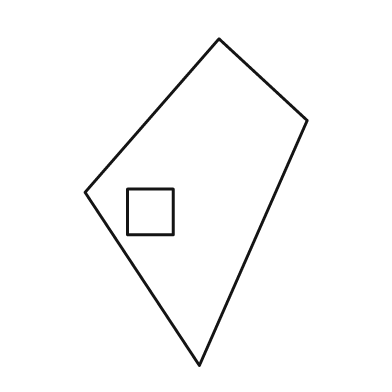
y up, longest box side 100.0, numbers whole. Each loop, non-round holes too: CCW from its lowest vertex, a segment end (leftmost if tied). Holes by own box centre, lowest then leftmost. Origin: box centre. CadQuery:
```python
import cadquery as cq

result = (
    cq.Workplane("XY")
    .moveTo(1.0, -50.0)
    .lineTo(34.0, 25.0)
    .lineTo(7.0, 50.0)
    .lineTo(-34.0, 3.0)
    .close()
    .moveTo(-21.0, -10.0)
    .lineTo(-7.0, -10.0)
    .lineTo(-7.0, 4.0)
    .lineTo(-21.0, 4.0)
    .close()
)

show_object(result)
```